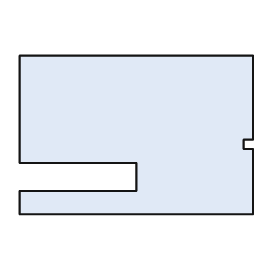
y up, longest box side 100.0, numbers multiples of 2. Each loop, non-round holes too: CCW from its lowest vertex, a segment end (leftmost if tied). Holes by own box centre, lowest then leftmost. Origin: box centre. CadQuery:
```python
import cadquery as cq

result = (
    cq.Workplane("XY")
    .moveTo(-50.0, -34.0)
    .lineTo(50.0, -34.0)
    .lineTo(50.0, -6.0)
    .lineTo(46.0, -6.0)
    .lineTo(46.0, -2.0)
    .lineTo(50.0, -2.0)
    .lineTo(50.0, 34.0)
    .lineTo(-50.0, 34.0)
    .lineTo(-50.0, -12.0)
    .lineTo(0.0, -12.0)
    .lineTo(0.0, -24.0)
    .lineTo(-50.0, -24.0)
    .close()
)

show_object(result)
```